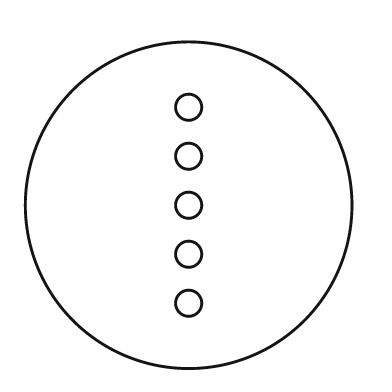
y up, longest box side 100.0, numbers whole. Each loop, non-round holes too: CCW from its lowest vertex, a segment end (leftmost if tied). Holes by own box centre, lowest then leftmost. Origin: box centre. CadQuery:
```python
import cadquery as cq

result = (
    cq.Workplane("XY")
    .moveTo(0.0, 0.0)
    .circle(50.0)
    .moveTo(0.0, -30.0)
    .circle(4.0)
    .moveTo(0.0, -15.0)
    .circle(4.0)
    .moveTo(0.0, 0.0)
    .circle(4.0)
    .moveTo(0.0, 15.0)
    .circle(4.0)
    .moveTo(0.0, 30.0)
    .circle(4.0)
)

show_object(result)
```